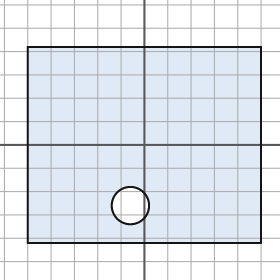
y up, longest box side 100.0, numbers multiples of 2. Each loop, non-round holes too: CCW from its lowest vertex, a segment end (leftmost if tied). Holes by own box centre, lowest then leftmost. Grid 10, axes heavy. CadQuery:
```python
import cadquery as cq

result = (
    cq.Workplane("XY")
    .moveTo(-50.0, -42.0)
    .lineTo(50.0, -42.0)
    .lineTo(50.0, 42.0)
    .lineTo(-50.0, 42.0)
    .close()
    .moveTo(-6.0, -26.0)
    .circle(8.0)
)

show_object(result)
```